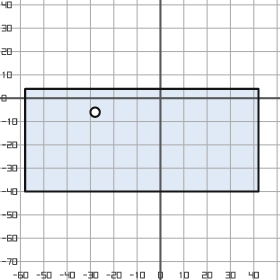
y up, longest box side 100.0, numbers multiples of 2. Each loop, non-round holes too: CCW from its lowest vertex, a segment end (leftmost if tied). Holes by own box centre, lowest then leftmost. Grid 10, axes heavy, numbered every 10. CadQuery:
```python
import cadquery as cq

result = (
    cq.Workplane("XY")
    .moveTo(-58.0, -40.0)
    .lineTo(42.0, -40.0)
    .lineTo(42.0, 4.0)
    .lineTo(-58.0, 4.0)
    .close()
    .moveTo(-28.0, -6.0)
    .circle(2.0)
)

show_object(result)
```